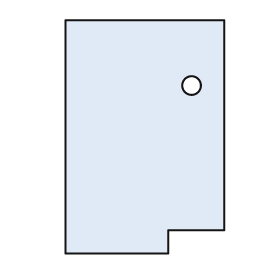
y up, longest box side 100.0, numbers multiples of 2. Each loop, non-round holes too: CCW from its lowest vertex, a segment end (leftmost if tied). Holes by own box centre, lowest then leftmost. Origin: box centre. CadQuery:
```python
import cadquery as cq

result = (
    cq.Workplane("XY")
    .moveTo(-34.0, -50.0)
    .lineTo(10.0, -50.0)
    .lineTo(10.0, -40.0)
    .lineTo(34.0, -40.0)
    .lineTo(34.0, 50.0)
    .lineTo(-34.0, 50.0)
    .close()
    .moveTo(20.0, 22.0)
    .circle(4.0)
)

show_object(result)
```